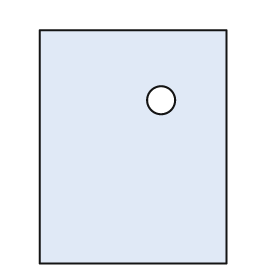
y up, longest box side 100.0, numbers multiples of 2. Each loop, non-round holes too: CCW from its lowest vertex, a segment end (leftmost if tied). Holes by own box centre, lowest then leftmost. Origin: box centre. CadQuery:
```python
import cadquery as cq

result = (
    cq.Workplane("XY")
    .moveTo(-40.0, -50.0)
    .lineTo(40.0, -50.0)
    .lineTo(40.0, 50.0)
    .lineTo(-40.0, 50.0)
    .close()
    .moveTo(12.0, 20.0)
    .circle(6.0)
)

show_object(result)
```